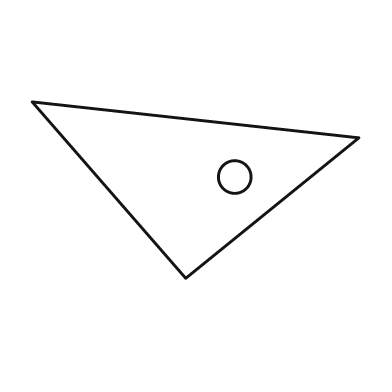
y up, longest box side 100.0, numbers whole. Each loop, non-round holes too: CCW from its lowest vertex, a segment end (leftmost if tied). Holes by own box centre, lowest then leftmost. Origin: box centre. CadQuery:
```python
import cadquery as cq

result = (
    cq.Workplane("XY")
    .moveTo(-3.0, -27.0)
    .lineTo(50.0, 16.0)
    .lineTo(-50.0, 27.0)
    .close()
    .moveTo(12.0, 4.0)
    .circle(5.0)
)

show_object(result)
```